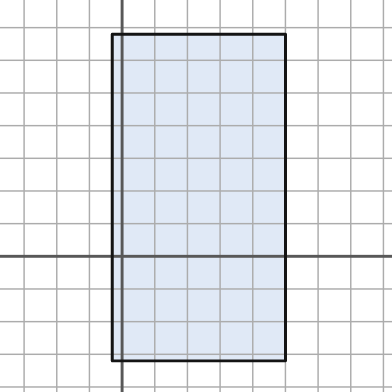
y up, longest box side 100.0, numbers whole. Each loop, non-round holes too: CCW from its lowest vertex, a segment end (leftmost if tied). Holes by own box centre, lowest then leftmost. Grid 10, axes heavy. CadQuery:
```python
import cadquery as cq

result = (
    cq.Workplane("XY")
    .moveTo(-3.0, -32.0)
    .lineTo(50.0, -32.0)
    .lineTo(50.0, 68.0)
    .lineTo(-3.0, 68.0)
    .close()
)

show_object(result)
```